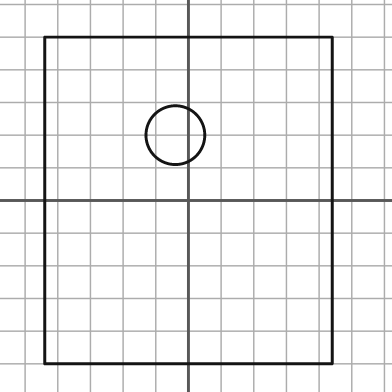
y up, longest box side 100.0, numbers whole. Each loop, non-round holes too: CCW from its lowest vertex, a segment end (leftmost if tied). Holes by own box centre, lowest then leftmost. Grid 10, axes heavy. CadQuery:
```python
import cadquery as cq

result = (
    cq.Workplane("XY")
    .moveTo(-44.0, -50.0)
    .lineTo(44.0, -50.0)
    .lineTo(44.0, 50.0)
    .lineTo(-44.0, 50.0)
    .close()
    .moveTo(-4.0, 20.0)
    .circle(9.0)
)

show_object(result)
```